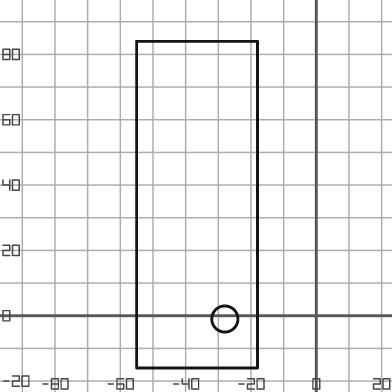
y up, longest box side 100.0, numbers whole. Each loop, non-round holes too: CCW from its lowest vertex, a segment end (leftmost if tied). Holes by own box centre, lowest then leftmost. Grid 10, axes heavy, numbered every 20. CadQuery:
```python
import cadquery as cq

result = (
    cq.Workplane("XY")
    .moveTo(-55.0, -16.0)
    .lineTo(-18.0, -16.0)
    .lineTo(-18.0, 84.0)
    .lineTo(-55.0, 84.0)
    .close()
    .moveTo(-28.0, -1.0)
    .circle(4.0)
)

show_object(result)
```